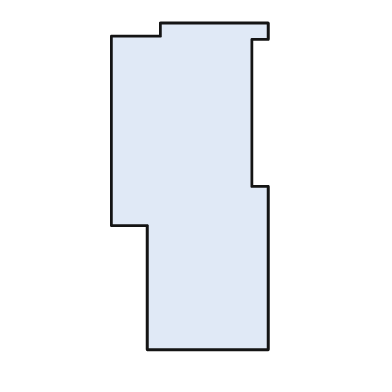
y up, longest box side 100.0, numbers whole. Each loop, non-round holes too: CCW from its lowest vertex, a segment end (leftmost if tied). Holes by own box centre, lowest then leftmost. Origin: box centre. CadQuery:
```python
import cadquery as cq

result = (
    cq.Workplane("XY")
    .moveTo(-13.0, -50.0)
    .lineTo(24.0, -50.0)
    .lineTo(24.0, 0.0)
    .lineTo(19.0, 0.0)
    .lineTo(19.0, 45.0)
    .lineTo(24.0, 45.0)
    .lineTo(24.0, 50.0)
    .lineTo(-9.0, 50.0)
    .lineTo(-9.0, 46.0)
    .lineTo(-24.0, 46.0)
    .lineTo(-24.0, -12.0)
    .lineTo(-13.0, -12.0)
    .close()
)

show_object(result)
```